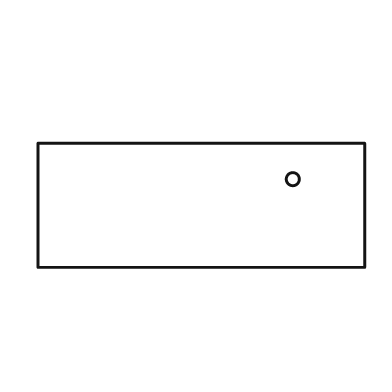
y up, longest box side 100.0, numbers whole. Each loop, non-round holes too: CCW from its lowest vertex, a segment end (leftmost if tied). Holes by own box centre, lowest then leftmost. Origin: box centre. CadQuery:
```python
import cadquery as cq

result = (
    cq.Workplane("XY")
    .moveTo(-50.0, -19.0)
    .lineTo(50.0, -19.0)
    .lineTo(50.0, 19.0)
    .lineTo(-50.0, 19.0)
    .close()
    .moveTo(28.0, 8.0)
    .circle(2.0)
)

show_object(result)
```